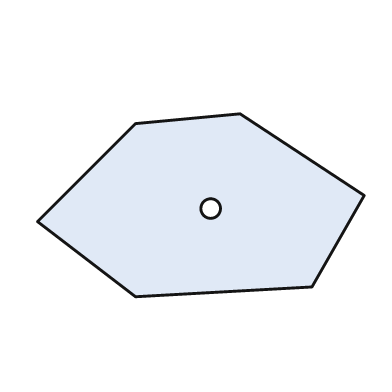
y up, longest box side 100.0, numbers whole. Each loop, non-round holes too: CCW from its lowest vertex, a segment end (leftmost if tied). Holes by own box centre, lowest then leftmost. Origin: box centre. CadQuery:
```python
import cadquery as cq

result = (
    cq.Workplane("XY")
    .moveTo(-20.0, -28.0)
    .lineTo(34.0, -25.0)
    .lineTo(50.0, 3.0)
    .lineTo(12.0, 28.0)
    .lineTo(-20.0, 25.0)
    .lineTo(-50.0, -5.0)
    .close()
    .moveTo(3.0, -1.0)
    .circle(3.0)
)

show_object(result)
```